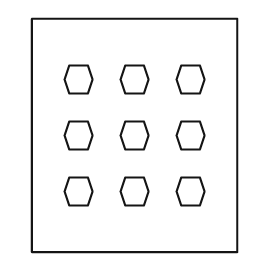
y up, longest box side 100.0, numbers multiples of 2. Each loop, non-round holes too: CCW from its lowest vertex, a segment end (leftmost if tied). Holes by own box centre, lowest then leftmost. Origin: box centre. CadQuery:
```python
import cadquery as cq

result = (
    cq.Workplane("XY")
    .moveTo(-44.0, -50.0)
    .lineTo(44.0, -50.0)
    .lineTo(44.0, 50.0)
    .lineTo(-44.0, 50.0)
    .close()
    .moveTo(-28.0, -30.0)
    .lineTo(-20.0, -30.0)
    .lineTo(-18.0, -24.0)
    .lineTo(-20.0, -18.0)
    .lineTo(-28.0, -18.0)
    .lineTo(-30.0, -24.0)
    .close()
    .moveTo(-4.0, -30.0)
    .lineTo(4.0, -30.0)
    .lineTo(6.0, -24.0)
    .lineTo(4.0, -18.0)
    .lineTo(-4.0, -18.0)
    .lineTo(-6.0, -24.0)
    .close()
    .moveTo(20.0, -30.0)
    .lineTo(28.0, -30.0)
    .lineTo(30.0, -24.0)
    .lineTo(28.0, -18.0)
    .lineTo(20.0, -18.0)
    .lineTo(18.0, -24.0)
    .close()
    .moveTo(-28.0, -6.0)
    .lineTo(-20.0, -6.0)
    .lineTo(-18.0, 0.0)
    .lineTo(-20.0, 6.0)
    .lineTo(-28.0, 6.0)
    .lineTo(-30.0, 0.0)
    .close()
    .moveTo(-4.0, -6.0)
    .lineTo(4.0, -6.0)
    .lineTo(6.0, 0.0)
    .lineTo(4.0, 6.0)
    .lineTo(-4.0, 6.0)
    .lineTo(-6.0, 0.0)
    .close()
    .moveTo(20.0, -6.0)
    .lineTo(28.0, -6.0)
    .lineTo(30.0, 0.0)
    .lineTo(28.0, 6.0)
    .lineTo(20.0, 6.0)
    .lineTo(18.0, 0.0)
    .close()
    .moveTo(-28.0, 18.0)
    .lineTo(-20.0, 18.0)
    .lineTo(-18.0, 24.0)
    .lineTo(-20.0, 30.0)
    .lineTo(-28.0, 30.0)
    .lineTo(-30.0, 24.0)
    .close()
    .moveTo(-4.0, 18.0)
    .lineTo(4.0, 18.0)
    .lineTo(6.0, 24.0)
    .lineTo(4.0, 30.0)
    .lineTo(-4.0, 30.0)
    .lineTo(-6.0, 24.0)
    .close()
    .moveTo(20.0, 18.0)
    .lineTo(28.0, 18.0)
    .lineTo(30.0, 24.0)
    .lineTo(28.0, 30.0)
    .lineTo(20.0, 30.0)
    .lineTo(18.0, 24.0)
    .close()
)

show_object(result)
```